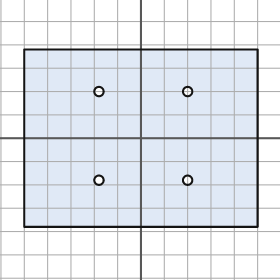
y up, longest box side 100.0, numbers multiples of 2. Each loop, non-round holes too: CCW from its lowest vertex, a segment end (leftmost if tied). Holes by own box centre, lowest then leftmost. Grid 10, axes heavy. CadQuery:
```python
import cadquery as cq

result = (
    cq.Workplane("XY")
    .moveTo(-50.0, -38.0)
    .lineTo(50.0, -38.0)
    .lineTo(50.0, 38.0)
    .lineTo(-50.0, 38.0)
    .close()
    .moveTo(-18.0, -18.0)
    .circle(2.0)
    .moveTo(20.0, -18.0)
    .circle(2.0)
    .moveTo(-18.0, 20.0)
    .circle(2.0)
    .moveTo(20.0, 20.0)
    .circle(2.0)
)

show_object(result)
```